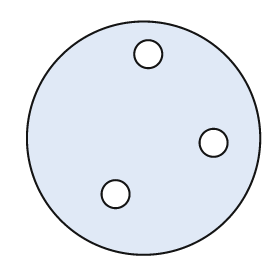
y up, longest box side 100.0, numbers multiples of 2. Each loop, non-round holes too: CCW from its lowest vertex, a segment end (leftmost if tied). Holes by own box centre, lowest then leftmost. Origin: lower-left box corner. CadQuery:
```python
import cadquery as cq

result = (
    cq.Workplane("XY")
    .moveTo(50.0, 50.0)
    .circle(50.0)
    .moveTo(38.0, 26.0)
    .circle(6.0)
    .moveTo(80.0, 48.0)
    .circle(6.0)
    .moveTo(52.0, 86.0)
    .circle(6.0)
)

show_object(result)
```